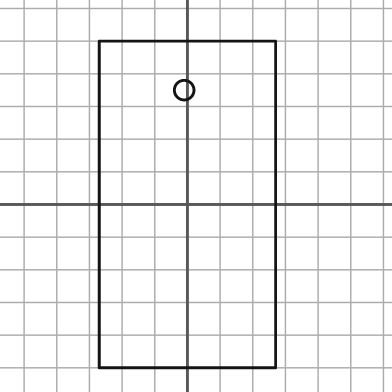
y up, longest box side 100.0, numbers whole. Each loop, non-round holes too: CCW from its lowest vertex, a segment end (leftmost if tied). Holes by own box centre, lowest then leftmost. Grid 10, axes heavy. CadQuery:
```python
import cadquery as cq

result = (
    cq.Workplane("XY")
    .moveTo(-27.0, -50.0)
    .lineTo(27.0, -50.0)
    .lineTo(27.0, 50.0)
    .lineTo(-27.0, 50.0)
    .close()
    .moveTo(-1.0, 35.0)
    .circle(3.0)
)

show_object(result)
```